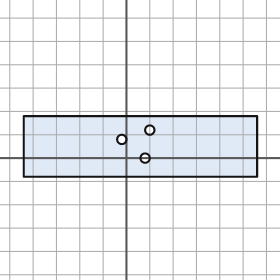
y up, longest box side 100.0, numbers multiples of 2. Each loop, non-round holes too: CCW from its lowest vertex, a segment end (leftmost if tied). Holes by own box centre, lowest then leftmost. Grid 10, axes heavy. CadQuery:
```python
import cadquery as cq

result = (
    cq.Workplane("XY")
    .moveTo(-44.0, -8.0)
    .lineTo(56.0, -8.0)
    .lineTo(56.0, 18.0)
    .lineTo(-44.0, 18.0)
    .close()
    .moveTo(8.0, 0.0)
    .circle(2.0)
    .moveTo(-2.0, 8.0)
    .circle(2.0)
    .moveTo(10.0, 12.0)
    .circle(2.0)
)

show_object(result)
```